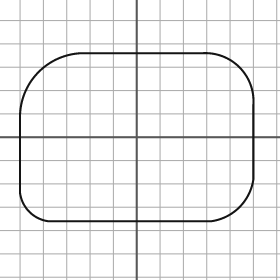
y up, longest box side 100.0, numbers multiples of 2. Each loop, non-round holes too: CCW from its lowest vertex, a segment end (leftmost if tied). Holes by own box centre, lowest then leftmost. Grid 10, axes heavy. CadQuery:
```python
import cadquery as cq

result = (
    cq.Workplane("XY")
    .moveTo(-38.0, -36.0)
    .lineTo(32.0, -36.0)
    .threePointArc((44.0, -30.0), (50.0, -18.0))
    .lineTo(50.0, 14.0)
    .threePointArc((44.0, 30.0), (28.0, 36.0))
    .lineTo(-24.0, 36.0)
    .threePointArc((-42.0, 28.0), (-50.0, 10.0))
    .lineTo(-50.0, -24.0)
    .threePointArc((-46.0, -32.0), (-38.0, -36.0))
    .close()
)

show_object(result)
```